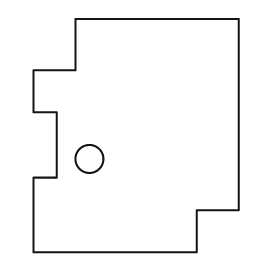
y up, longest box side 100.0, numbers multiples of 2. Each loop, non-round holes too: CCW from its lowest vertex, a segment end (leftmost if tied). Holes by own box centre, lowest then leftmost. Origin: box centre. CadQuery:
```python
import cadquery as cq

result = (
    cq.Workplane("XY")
    .moveTo(-44.0, -50.0)
    .lineTo(26.0, -50.0)
    .lineTo(26.0, -32.0)
    .lineTo(44.0, -32.0)
    .lineTo(44.0, 50.0)
    .lineTo(-26.0, 50.0)
    .lineTo(-26.0, 28.0)
    .lineTo(-44.0, 28.0)
    .lineTo(-44.0, 10.0)
    .lineTo(-34.0, 10.0)
    .lineTo(-34.0, -18.0)
    .lineTo(-44.0, -18.0)
    .close()
    .moveTo(-20.0, -10.0)
    .circle(6.0)
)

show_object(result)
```